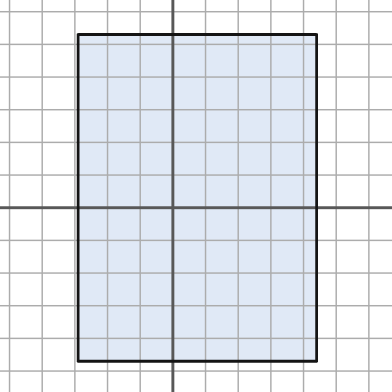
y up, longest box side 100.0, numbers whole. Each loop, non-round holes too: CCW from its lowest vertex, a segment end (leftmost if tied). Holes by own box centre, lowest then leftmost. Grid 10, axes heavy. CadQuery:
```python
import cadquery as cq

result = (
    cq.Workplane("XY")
    .moveTo(-29.0, -47.0)
    .lineTo(44.0, -47.0)
    .lineTo(44.0, 53.0)
    .lineTo(-29.0, 53.0)
    .close()
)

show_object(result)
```